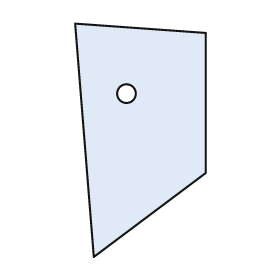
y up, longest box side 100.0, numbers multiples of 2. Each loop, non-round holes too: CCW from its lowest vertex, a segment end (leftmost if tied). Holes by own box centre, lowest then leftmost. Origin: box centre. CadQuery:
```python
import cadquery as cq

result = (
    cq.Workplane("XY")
    .moveTo(-20.0, -50.0)
    .lineTo(28.0, -14.0)
    .lineTo(28.0, 46.0)
    .lineTo(-28.0, 50.0)
    .close()
    .moveTo(-6.0, 20.0)
    .circle(4.0)
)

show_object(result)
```